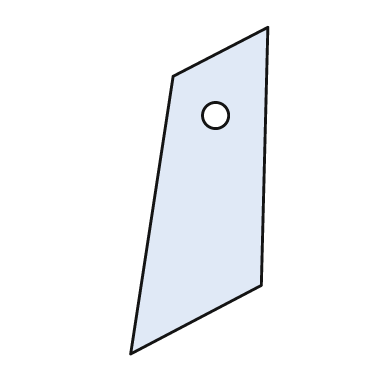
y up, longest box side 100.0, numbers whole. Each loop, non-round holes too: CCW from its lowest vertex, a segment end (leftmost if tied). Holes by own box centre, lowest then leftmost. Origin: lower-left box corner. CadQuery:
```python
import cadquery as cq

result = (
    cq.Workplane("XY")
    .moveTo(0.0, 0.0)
    .lineTo(40.0, 21.0)
    .lineTo(42.0, 100.0)
    .lineTo(13.0, 85.0)
    .close()
    .moveTo(26.0, 73.0)
    .circle(4.0)
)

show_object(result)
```